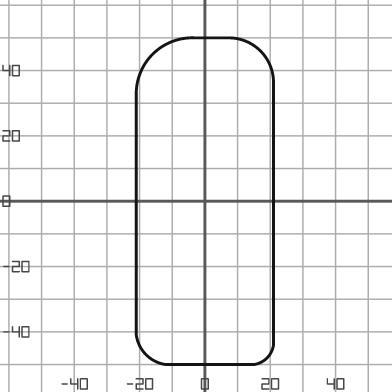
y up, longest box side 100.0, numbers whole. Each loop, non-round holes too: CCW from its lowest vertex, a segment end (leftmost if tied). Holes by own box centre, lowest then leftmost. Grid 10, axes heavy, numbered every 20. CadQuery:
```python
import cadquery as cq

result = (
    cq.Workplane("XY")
    .moveTo(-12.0, -50.0)
    .lineTo(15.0, -50.0)
    .threePointArc((19.0, -48.0), (21.0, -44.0))
    .lineTo(21.0, 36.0)
    .threePointArc((17.0, 46.0), (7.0, 50.0))
    .lineTo(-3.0, 50.0)
    .threePointArc((-16.0, 45.0), (-21.0, 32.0))
    .lineTo(-21.0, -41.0)
    .threePointArc((-18.0, -47.0), (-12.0, -50.0))
    .close()
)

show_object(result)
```